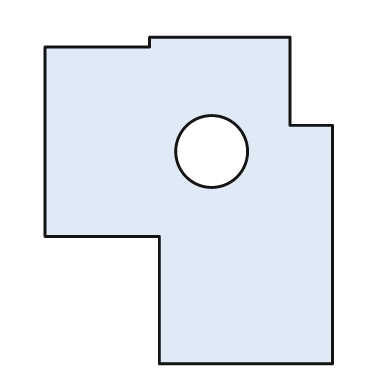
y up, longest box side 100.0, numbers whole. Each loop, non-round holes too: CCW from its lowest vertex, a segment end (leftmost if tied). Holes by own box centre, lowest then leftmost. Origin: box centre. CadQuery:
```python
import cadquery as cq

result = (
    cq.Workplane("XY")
    .moveTo(-9.0, -50.0)
    .lineTo(44.0, -50.0)
    .lineTo(44.0, 23.0)
    .lineTo(31.0, 23.0)
    .lineTo(31.0, 50.0)
    .lineTo(-12.0, 50.0)
    .lineTo(-12.0, 47.0)
    .lineTo(-44.0, 47.0)
    .lineTo(-44.0, -11.0)
    .lineTo(-9.0, -11.0)
    .close()
    .moveTo(7.0, 15.0)
    .circle(11.0)
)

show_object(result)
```